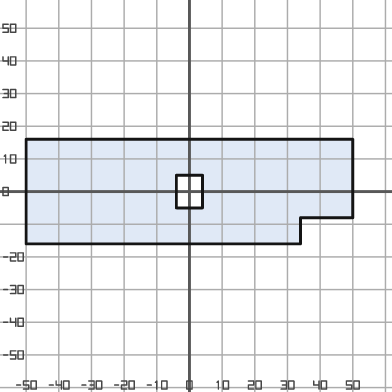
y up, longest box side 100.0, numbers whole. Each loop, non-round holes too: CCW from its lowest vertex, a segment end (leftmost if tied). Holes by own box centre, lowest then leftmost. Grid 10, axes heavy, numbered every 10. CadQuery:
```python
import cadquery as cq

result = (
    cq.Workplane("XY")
    .moveTo(-50.0, -16.0)
    .lineTo(34.0, -16.0)
    .lineTo(34.0, -8.0)
    .lineTo(50.0, -8.0)
    .lineTo(50.0, 16.0)
    .lineTo(-50.0, 16.0)
    .close()
    .moveTo(-4.0, -5.0)
    .lineTo(4.0, -5.0)
    .lineTo(4.0, 5.0)
    .lineTo(-4.0, 5.0)
    .close()
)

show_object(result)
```